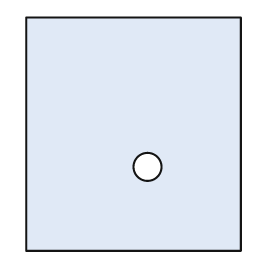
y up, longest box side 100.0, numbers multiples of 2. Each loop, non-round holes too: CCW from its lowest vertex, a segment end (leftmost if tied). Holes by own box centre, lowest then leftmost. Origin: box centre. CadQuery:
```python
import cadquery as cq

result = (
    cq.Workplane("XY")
    .moveTo(-46.0, -50.0)
    .lineTo(46.0, -50.0)
    .lineTo(46.0, 50.0)
    .lineTo(-46.0, 50.0)
    .close()
    .moveTo(6.0, -14.0)
    .circle(6.0)
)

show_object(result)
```